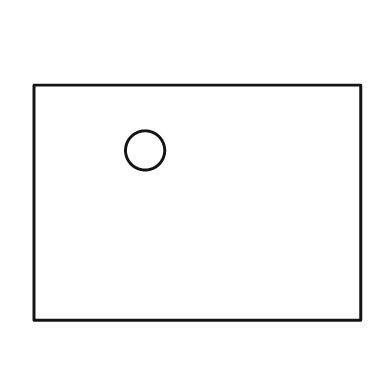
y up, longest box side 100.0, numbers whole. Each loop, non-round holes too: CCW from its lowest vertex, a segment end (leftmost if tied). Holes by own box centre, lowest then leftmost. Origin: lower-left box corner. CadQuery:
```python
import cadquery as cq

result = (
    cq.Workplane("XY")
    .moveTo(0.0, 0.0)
    .lineTo(100.0, 0.0)
    .lineTo(100.0, 72.0)
    .lineTo(0.0, 72.0)
    .close()
    .moveTo(34.0, 52.0)
    .circle(6.0)
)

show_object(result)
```